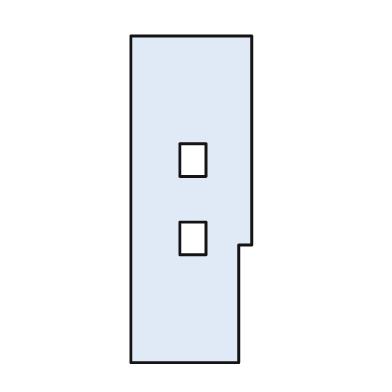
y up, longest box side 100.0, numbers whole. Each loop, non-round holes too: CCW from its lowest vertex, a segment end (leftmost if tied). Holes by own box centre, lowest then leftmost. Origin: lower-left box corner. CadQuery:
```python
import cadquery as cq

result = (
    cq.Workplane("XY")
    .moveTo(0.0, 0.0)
    .lineTo(33.0, 0.0)
    .lineTo(33.0, 36.0)
    .lineTo(37.0, 36.0)
    .lineTo(37.0, 100.0)
    .lineTo(0.0, 100.0)
    .close()
    .moveTo(15.0, 33.0)
    .lineTo(23.0, 33.0)
    .lineTo(23.0, 43.0)
    .lineTo(15.0, 43.0)
    .close()
    .moveTo(15.0, 57.0)
    .lineTo(23.0, 57.0)
    .lineTo(23.0, 67.0)
    .lineTo(15.0, 67.0)
    .close()
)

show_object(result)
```